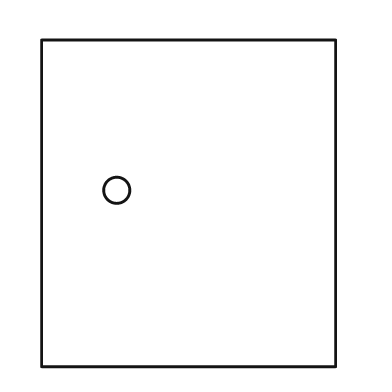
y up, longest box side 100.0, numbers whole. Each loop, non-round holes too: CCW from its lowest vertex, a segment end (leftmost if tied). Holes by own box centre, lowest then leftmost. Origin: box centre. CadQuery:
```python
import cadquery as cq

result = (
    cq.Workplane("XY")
    .moveTo(-45.0, -50.0)
    .lineTo(45.0, -50.0)
    .lineTo(45.0, 50.0)
    .lineTo(-45.0, 50.0)
    .close()
    .moveTo(-22.0, 4.0)
    .circle(4.0)
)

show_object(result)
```